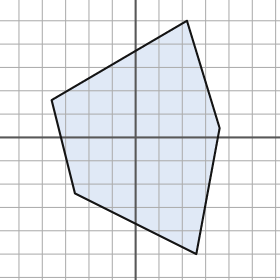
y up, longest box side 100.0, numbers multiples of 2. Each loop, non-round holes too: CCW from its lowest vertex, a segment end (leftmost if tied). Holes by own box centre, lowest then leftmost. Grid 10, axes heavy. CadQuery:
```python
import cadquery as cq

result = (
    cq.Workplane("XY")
    .moveTo(26.0, -50.0)
    .lineTo(36.0, 4.0)
    .lineTo(22.0, 50.0)
    .lineTo(-36.0, 16.0)
    .lineTo(-26.0, -24.0)
    .close()
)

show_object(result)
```